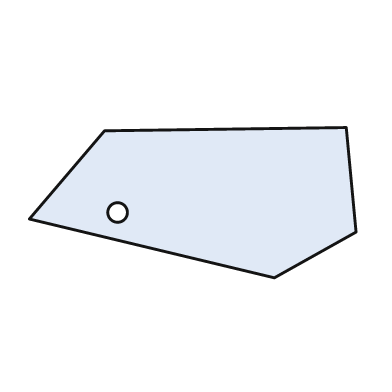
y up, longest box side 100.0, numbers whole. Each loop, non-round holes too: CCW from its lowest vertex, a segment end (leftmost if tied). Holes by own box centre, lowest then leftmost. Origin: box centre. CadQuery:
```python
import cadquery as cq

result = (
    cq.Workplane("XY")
    .moveTo(25.0, -23.0)
    .lineTo(50.0, -9.0)
    .lineTo(47.0, 23.0)
    .lineTo(-27.0, 22.0)
    .lineTo(-50.0, -5.0)
    .close()
    .moveTo(-23.0, -3.0)
    .circle(3.0)
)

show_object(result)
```